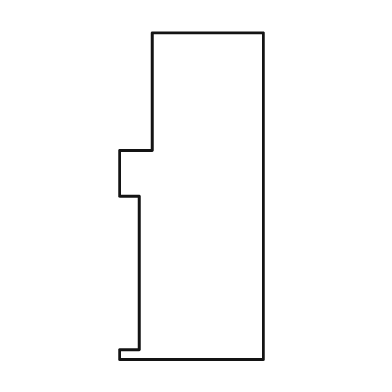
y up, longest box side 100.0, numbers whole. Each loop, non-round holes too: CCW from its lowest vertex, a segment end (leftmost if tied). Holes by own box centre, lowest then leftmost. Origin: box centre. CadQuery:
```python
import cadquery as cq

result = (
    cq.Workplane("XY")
    .moveTo(-22.0, -50.0)
    .lineTo(22.0, -50.0)
    .lineTo(22.0, 50.0)
    .lineTo(-12.0, 50.0)
    .lineTo(-12.0, 14.0)
    .lineTo(-22.0, 14.0)
    .lineTo(-22.0, 0.0)
    .lineTo(-16.0, 0.0)
    .lineTo(-16.0, -47.0)
    .lineTo(-22.0, -47.0)
    .close()
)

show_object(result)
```